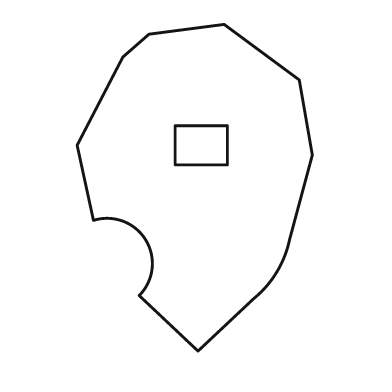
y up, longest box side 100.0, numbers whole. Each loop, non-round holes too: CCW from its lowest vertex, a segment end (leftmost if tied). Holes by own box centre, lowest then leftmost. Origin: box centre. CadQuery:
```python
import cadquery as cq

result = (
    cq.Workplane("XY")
    .moveTo(1.0, -50.0)
    .lineTo(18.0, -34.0)
    .threePointArc((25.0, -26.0), (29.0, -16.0))
    .lineTo(36.0, 10.0)
    .lineTo(32.0, 33.0)
    .lineTo(9.0, 50.0)
    .lineTo(-14.0, 47.0)
    .lineTo(-22.0, 40.0)
    .lineTo(-36.0, 13.0)
    .lineTo(-31.0, -10.0)
    .threePointArc((-15.0, -16.0), (-17.0, -33.0))
    .close()
    .moveTo(-6.0, 7.0)
    .lineTo(10.0, 7.0)
    .lineTo(10.0, 19.0)
    .lineTo(-6.0, 19.0)
    .close()
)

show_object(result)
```